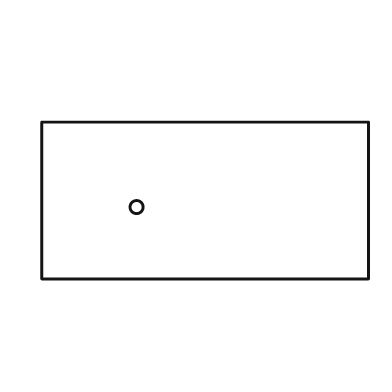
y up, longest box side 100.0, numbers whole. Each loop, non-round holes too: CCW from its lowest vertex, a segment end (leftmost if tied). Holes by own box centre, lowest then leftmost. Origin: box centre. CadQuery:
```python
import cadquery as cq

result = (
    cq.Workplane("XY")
    .moveTo(-50.0, -24.0)
    .lineTo(50.0, -24.0)
    .lineTo(50.0, 24.0)
    .lineTo(-50.0, 24.0)
    .close()
    .moveTo(-21.0, -2.0)
    .circle(2.0)
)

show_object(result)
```